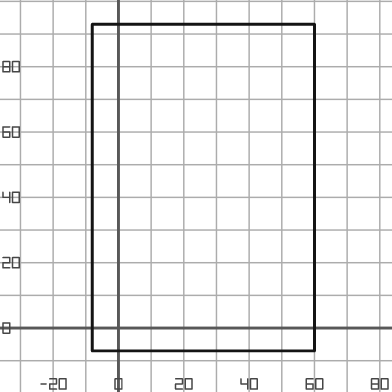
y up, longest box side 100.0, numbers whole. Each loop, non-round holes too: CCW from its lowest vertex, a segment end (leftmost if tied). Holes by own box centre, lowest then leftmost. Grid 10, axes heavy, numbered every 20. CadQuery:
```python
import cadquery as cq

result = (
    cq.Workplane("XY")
    .moveTo(-8.0, -7.0)
    .lineTo(60.0, -7.0)
    .lineTo(60.0, 93.0)
    .lineTo(-8.0, 93.0)
    .close()
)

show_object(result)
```